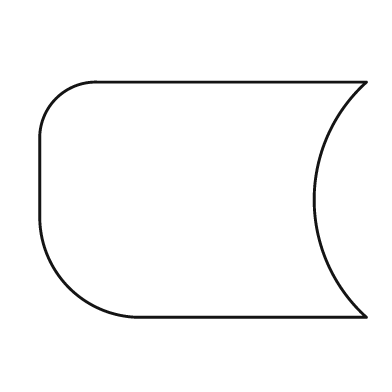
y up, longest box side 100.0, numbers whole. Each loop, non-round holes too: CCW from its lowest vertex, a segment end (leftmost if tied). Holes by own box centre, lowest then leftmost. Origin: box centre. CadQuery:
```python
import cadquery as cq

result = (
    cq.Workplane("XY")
    .moveTo(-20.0, -36.0)
    .lineTo(50.0, -36.0)
    .threePointArc((34.0, 0.0), (50.0, 36.0))
    .lineTo(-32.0, 36.0)
    .threePointArc((-45.0, 31.0), (-50.0, 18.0))
    .lineTo(-50.0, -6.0)
    .threePointArc((-41.0, -27.0), (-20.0, -36.0))
    .close()
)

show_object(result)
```